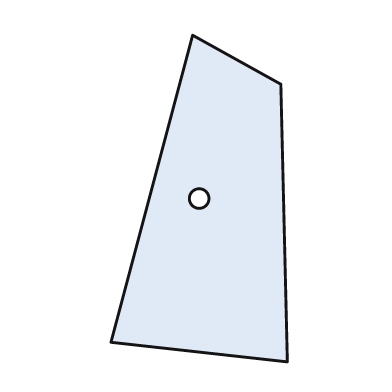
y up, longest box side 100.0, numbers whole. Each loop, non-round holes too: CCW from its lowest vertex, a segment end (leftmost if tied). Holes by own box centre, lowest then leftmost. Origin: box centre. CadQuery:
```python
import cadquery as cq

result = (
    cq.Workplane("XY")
    .moveTo(27.0, -50.0)
    .lineTo(25.0, 35.0)
    .lineTo(-2.0, 50.0)
    .lineTo(-27.0, -44.0)
    .close()
    .moveTo(0.0, 0.0)
    .circle(3.0)
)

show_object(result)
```